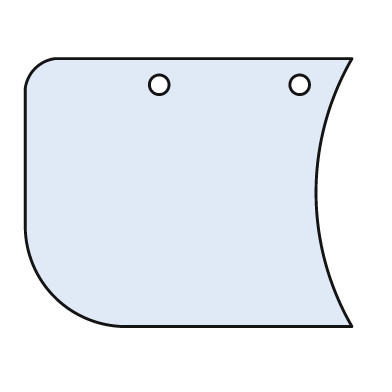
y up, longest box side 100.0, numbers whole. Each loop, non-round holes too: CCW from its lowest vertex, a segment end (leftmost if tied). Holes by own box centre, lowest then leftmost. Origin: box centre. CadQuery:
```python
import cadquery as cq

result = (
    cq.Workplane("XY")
    .moveTo(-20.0, -41.0)
    .lineTo(50.0, -41.0)
    .threePointArc((39.0, 0.0), (50.0, 41.0))
    .lineTo(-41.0, 41.0)
    .threePointArc((-47.0, 38.0), (-50.0, 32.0))
    .lineTo(-50.0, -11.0)
    .threePointArc((-41.0, -32.0), (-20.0, -41.0))
    .close()
    .moveTo(-9.0, 33.0)
    .circle(3.0)
    .moveTo(34.0, 33.0)
    .circle(3.0)
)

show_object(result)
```